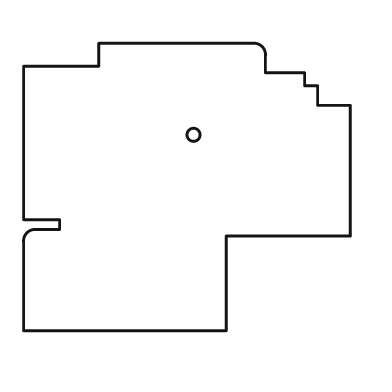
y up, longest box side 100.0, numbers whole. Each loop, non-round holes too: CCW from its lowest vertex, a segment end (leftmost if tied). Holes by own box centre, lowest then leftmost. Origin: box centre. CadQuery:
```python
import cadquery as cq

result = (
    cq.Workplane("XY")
    .moveTo(-50.0, -44.0)
    .lineTo(12.0, -44.0)
    .lineTo(12.0, -15.0)
    .lineTo(50.0, -15.0)
    .lineTo(50.0, 25.0)
    .lineTo(40.0, 25.0)
    .lineTo(40.0, 31.0)
    .lineTo(36.0, 31.0)
    .lineTo(36.0, 35.0)
    .lineTo(24.0, 35.0)
    .lineTo(24.0, 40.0)
    .threePointArc((23.0, 43.0), (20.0, 44.0))
    .lineTo(-27.0, 44.0)
    .lineTo(-27.0, 37.0)
    .lineTo(-50.0, 37.0)
    .lineTo(-50.0, -10.0)
    .lineTo(-39.0, -10.0)
    .lineTo(-39.0, -13.0)
    .lineTo(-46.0, -13.0)
    .threePointArc((-49.0, -14.0), (-50.0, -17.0))
    .close()
    .moveTo(2.0, 16.0)
    .circle(2.0)
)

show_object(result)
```